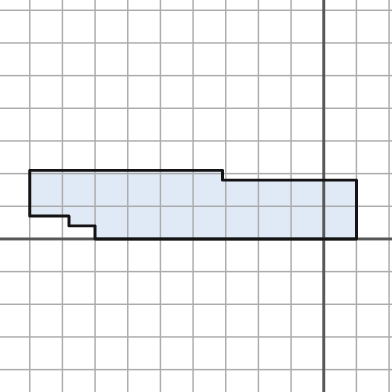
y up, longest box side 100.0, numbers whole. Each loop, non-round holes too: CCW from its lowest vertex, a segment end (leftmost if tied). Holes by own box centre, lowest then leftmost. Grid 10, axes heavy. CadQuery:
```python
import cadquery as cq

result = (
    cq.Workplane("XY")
    .moveTo(-70.0, 0.0)
    .lineTo(10.0, 0.0)
    .lineTo(10.0, 18.0)
    .lineTo(-31.0, 18.0)
    .lineTo(-31.0, 21.0)
    .lineTo(-90.0, 21.0)
    .lineTo(-90.0, 7.0)
    .lineTo(-78.0, 7.0)
    .lineTo(-78.0, 4.0)
    .lineTo(-70.0, 4.0)
    .close()
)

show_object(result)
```